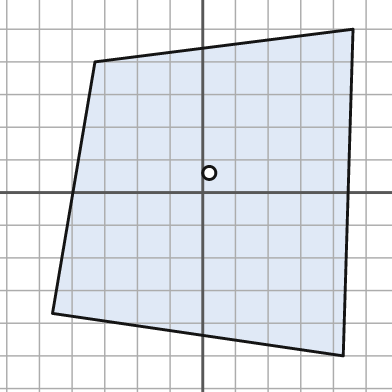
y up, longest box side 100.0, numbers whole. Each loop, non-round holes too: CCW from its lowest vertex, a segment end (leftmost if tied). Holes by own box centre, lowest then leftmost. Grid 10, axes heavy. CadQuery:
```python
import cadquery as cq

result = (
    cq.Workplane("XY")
    .moveTo(43.0, -50.0)
    .lineTo(46.0, 50.0)
    .lineTo(-33.0, 40.0)
    .lineTo(-46.0, -37.0)
    .close()
    .moveTo(2.0, 6.0)
    .circle(2.0)
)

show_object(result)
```